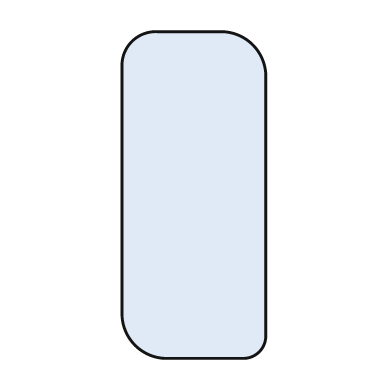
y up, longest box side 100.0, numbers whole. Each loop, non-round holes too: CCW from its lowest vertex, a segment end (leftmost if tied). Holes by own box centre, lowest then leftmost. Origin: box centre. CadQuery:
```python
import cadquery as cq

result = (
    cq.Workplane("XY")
    .moveTo(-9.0, -50.0)
    .lineTo(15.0, -50.0)
    .threePointArc((20.0, -48.0), (22.0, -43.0))
    .lineTo(22.0, 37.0)
    .threePointArc((18.0, 46.0), (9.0, 50.0))
    .lineTo(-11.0, 50.0)
    .threePointArc((-19.0, 47.0), (-22.0, 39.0))
    .lineTo(-22.0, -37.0)
    .threePointArc((-18.0, -46.0), (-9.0, -50.0))
    .close()
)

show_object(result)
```